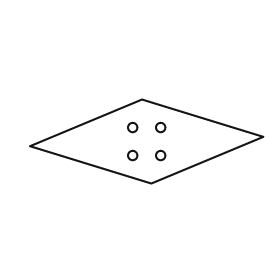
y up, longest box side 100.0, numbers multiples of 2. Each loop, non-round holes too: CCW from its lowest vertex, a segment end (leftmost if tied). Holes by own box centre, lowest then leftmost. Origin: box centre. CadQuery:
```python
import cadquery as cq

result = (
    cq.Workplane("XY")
    .moveTo(2.0, -18.0)
    .lineTo(50.0, 2.0)
    .lineTo(-2.0, 18.0)
    .lineTo(-50.0, -2.0)
    .close()
    .moveTo(-6.0, -6.0)
    .circle(2.0)
    .moveTo(6.0, -6.0)
    .circle(2.0)
    .moveTo(-6.0, 6.0)
    .circle(2.0)
    .moveTo(6.0, 6.0)
    .circle(2.0)
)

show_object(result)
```